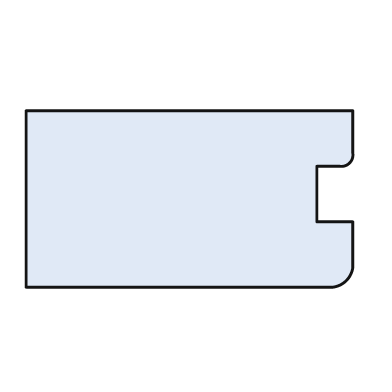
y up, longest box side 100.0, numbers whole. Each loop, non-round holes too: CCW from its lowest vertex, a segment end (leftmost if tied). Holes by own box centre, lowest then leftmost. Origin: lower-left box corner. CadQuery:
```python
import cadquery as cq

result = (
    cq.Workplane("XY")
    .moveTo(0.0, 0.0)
    .lineTo(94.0, 0.0)
    .threePointArc((98.0, 2.0), (100.0, 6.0))
    .lineTo(100.0, 20.0)
    .lineTo(89.0, 20.0)
    .lineTo(89.0, 37.0)
    .lineTo(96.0, 37.0)
    .threePointArc((99.0, 38.0), (100.0, 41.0))
    .lineTo(100.0, 54.0)
    .lineTo(0.0, 54.0)
    .close()
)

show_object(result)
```